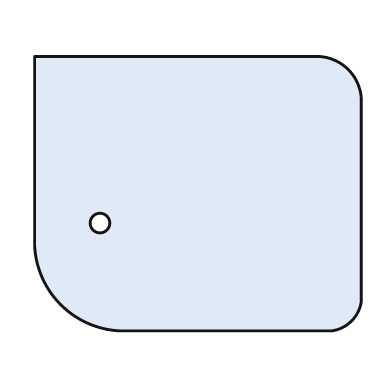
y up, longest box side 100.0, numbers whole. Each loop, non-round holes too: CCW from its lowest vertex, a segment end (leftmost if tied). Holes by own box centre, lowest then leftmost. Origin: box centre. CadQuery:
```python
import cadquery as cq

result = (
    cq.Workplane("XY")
    .moveTo(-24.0, -42.0)
    .lineTo(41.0, -42.0)
    .threePointArc((47.0, -39.0), (50.0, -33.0))
    .lineTo(50.0, 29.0)
    .threePointArc((46.0, 38.0), (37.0, 42.0))
    .lineTo(-50.0, 42.0)
    .lineTo(-50.0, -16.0)
    .threePointArc((-42.0, -34.0), (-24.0, -42.0))
    .close()
    .moveTo(-30.0, -9.0)
    .circle(3.0)
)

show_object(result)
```